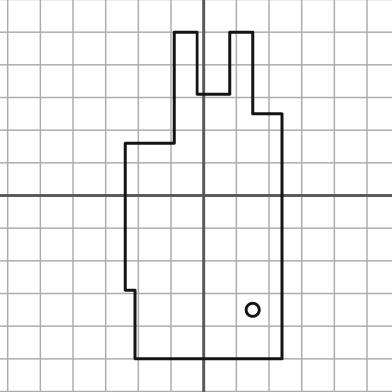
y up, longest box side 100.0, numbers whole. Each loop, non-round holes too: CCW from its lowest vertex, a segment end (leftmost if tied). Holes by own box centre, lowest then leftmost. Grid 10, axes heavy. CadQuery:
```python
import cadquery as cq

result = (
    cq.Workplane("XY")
    .moveTo(-21.0, -50.0)
    .lineTo(24.0, -50.0)
    .lineTo(24.0, 25.0)
    .lineTo(15.0, 25.0)
    .lineTo(15.0, 50.0)
    .lineTo(8.0, 50.0)
    .lineTo(8.0, 31.0)
    .lineTo(-2.0, 31.0)
    .lineTo(-2.0, 50.0)
    .lineTo(-9.0, 50.0)
    .lineTo(-9.0, 16.0)
    .lineTo(-24.0, 16.0)
    .lineTo(-24.0, -29.0)
    .lineTo(-21.0, -29.0)
    .close()
    .moveTo(15.0, -35.0)
    .circle(2.0)
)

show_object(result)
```